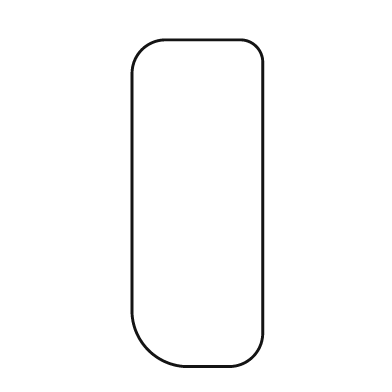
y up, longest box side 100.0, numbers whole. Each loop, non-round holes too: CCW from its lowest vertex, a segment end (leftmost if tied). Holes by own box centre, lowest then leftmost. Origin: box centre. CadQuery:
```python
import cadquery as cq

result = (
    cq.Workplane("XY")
    .moveTo(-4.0, -50.0)
    .lineTo(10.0, -50.0)
    .threePointArc((17.0, -47.0), (20.0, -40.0))
    .lineTo(20.0, 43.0)
    .threePointArc((18.0, 48.0), (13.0, 50.0))
    .lineTo(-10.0, 50.0)
    .threePointArc((-17.0, 47.0), (-20.0, 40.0))
    .lineTo(-20.0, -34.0)
    .threePointArc((-15.0, -45.0), (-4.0, -50.0))
    .close()
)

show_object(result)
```